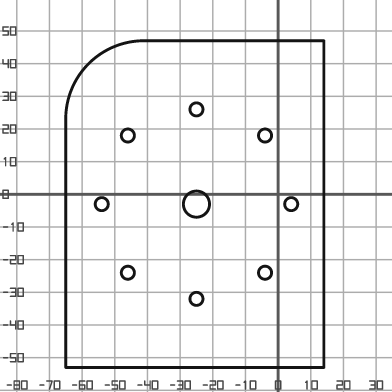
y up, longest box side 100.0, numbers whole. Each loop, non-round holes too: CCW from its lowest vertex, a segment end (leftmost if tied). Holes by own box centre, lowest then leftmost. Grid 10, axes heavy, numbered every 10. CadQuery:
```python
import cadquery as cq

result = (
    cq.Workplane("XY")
    .moveTo(-65.0, -53.0)
    .lineTo(14.0, -53.0)
    .lineTo(14.0, 47.0)
    .lineTo(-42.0, 47.0)
    .threePointArc((-58.0, 40.0), (-65.0, 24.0))
    .close()
    .moveTo(-25.0, -32.0)
    .circle(2.0)
    .moveTo(-46.0, -24.0)
    .circle(2.0)
    .moveTo(-4.0, -24.0)
    .circle(2.0)
    .moveTo(-54.0, -3.0)
    .circle(2.0)
    .moveTo(-25.0, -3.0)
    .circle(4.0)
    .moveTo(4.0, -3.0)
    .circle(2.0)
    .moveTo(-46.0, 18.0)
    .circle(2.0)
    .moveTo(-4.0, 18.0)
    .circle(2.0)
    .moveTo(-25.0, 26.0)
    .circle(2.0)
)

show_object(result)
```